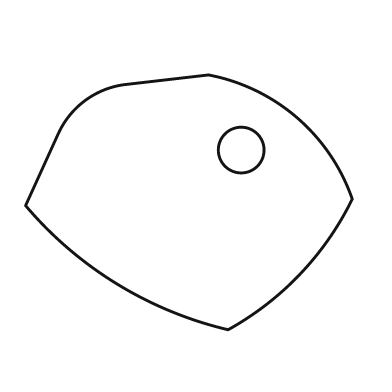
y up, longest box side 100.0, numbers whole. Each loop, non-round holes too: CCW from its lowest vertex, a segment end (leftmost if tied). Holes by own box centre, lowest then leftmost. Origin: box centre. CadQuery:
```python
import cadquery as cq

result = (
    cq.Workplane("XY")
    .moveTo(12.0, -39.0)
    .threePointArc((34.0, -22.0), (50.0, 1.0))
    .threePointArc((33.0, 26.0), (6.0, 39.0))
    .lineTo(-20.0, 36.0)
    .threePointArc((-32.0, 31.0), (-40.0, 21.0))
    .lineTo(-50.0, -1.0)
    .threePointArc((-22.0, -25.0), (12.0, -39.0))
    .close()
    .moveTo(16.0, 16.0)
    .circle(7.0)
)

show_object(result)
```